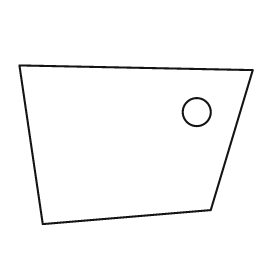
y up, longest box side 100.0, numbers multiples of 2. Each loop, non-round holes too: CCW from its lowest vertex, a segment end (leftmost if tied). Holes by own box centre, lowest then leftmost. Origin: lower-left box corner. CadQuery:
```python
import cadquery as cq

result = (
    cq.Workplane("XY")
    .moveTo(10.0, 0.0)
    .lineTo(82.0, 6.0)
    .lineTo(100.0, 66.0)
    .lineTo(0.0, 68.0)
    .close()
    .moveTo(76.0, 48.0)
    .circle(6.0)
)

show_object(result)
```